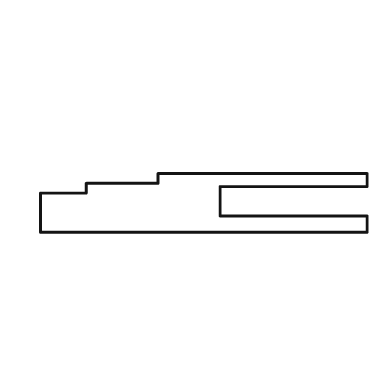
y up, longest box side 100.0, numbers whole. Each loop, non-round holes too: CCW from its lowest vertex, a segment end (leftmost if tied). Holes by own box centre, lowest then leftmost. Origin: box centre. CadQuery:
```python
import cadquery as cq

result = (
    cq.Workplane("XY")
    .moveTo(-50.0, -9.0)
    .lineTo(50.0, -9.0)
    .lineTo(50.0, -4.0)
    .lineTo(5.0, -4.0)
    .lineTo(5.0, 5.0)
    .lineTo(50.0, 5.0)
    .lineTo(50.0, 9.0)
    .lineTo(-14.0, 9.0)
    .lineTo(-14.0, 6.0)
    .lineTo(-36.0, 6.0)
    .lineTo(-36.0, 3.0)
    .lineTo(-50.0, 3.0)
    .close()
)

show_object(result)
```